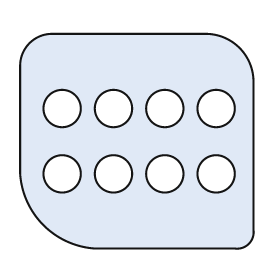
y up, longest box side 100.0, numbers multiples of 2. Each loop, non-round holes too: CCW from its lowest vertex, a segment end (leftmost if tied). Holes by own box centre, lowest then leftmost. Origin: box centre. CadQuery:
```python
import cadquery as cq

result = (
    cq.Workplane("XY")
    .moveTo(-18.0, -46.0)
    .lineTo(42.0, -46.0)
    .threePointArc((48.0, -44.0), (50.0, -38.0))
    .lineTo(50.0, 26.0)
    .threePointArc((44.0, 40.0), (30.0, 46.0))
    .lineTo(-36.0, 46.0)
    .threePointArc((-46.0, 42.0), (-50.0, 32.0))
    .lineTo(-50.0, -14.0)
    .threePointArc((-40.0, -36.0), (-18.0, -46.0))
    .close()
    .moveTo(-32.0, -14.0)
    .circle(8.0)
    .moveTo(-10.0, -14.0)
    .circle(8.0)
    .moveTo(12.0, -14.0)
    .circle(8.0)
    .moveTo(34.0, -14.0)
    .circle(8.0)
    .moveTo(-32.0, 14.0)
    .circle(8.0)
    .moveTo(-10.0, 14.0)
    .circle(8.0)
    .moveTo(12.0, 14.0)
    .circle(8.0)
    .moveTo(34.0, 14.0)
    .circle(8.0)
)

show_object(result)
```